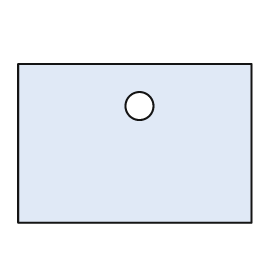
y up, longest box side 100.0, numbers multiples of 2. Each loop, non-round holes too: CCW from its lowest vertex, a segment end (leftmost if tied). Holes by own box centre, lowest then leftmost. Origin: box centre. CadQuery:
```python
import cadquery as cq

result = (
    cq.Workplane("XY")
    .moveTo(-50.0, -34.0)
    .lineTo(50.0, -34.0)
    .lineTo(50.0, 34.0)
    .lineTo(-50.0, 34.0)
    .close()
    .moveTo(2.0, 16.0)
    .circle(6.0)
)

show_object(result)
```